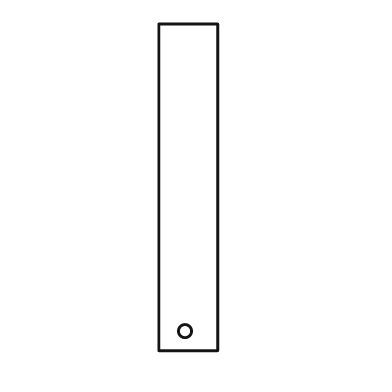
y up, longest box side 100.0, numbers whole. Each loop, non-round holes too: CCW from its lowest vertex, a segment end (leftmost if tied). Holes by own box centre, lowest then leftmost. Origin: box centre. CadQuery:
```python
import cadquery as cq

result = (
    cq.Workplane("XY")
    .moveTo(-9.0, -50.0)
    .lineTo(9.0, -50.0)
    .lineTo(9.0, 50.0)
    .lineTo(-9.0, 50.0)
    .close()
    .moveTo(-1.0, -44.0)
    .circle(2.0)
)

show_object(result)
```